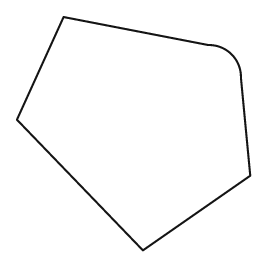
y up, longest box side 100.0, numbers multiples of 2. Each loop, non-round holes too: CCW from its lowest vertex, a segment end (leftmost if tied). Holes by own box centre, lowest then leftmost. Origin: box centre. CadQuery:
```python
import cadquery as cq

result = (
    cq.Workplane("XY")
    .moveTo(4.0, -50.0)
    .lineTo(50.0, -18.0)
    .lineTo(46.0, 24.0)
    .threePointArc((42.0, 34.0), (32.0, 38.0))
    .lineTo(-30.0, 50.0)
    .lineTo(-50.0, 6.0)
    .close()
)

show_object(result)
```